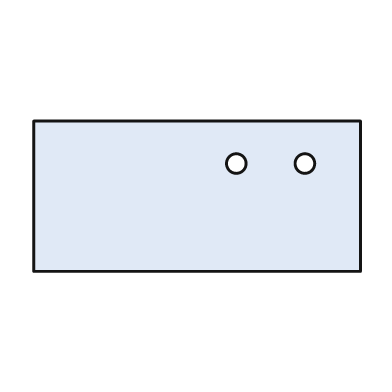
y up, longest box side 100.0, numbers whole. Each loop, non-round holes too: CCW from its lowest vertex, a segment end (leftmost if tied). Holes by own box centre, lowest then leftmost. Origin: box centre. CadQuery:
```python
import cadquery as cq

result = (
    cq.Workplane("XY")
    .moveTo(-50.0, -23.0)
    .lineTo(50.0, -23.0)
    .lineTo(50.0, 23.0)
    .lineTo(-50.0, 23.0)
    .close()
    .moveTo(12.0, 10.0)
    .circle(3.0)
    .moveTo(33.0, 10.0)
    .circle(3.0)
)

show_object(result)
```